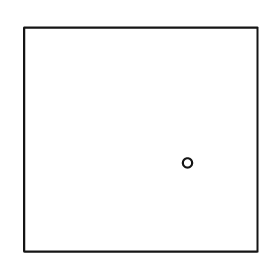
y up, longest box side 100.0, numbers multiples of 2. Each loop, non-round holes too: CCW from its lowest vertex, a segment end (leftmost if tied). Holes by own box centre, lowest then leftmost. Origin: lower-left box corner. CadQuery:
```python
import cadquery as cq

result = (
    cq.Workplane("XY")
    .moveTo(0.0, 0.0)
    .lineTo(100.0, 0.0)
    .lineTo(100.0, 96.0)
    .lineTo(0.0, 96.0)
    .close()
    .moveTo(70.0, 38.0)
    .circle(2.0)
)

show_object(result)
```